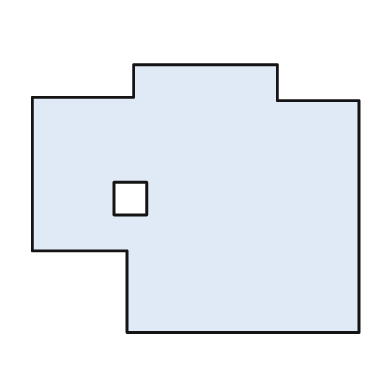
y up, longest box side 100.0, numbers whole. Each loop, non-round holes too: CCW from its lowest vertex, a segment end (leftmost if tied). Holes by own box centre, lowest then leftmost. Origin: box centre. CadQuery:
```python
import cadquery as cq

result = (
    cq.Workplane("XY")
    .moveTo(-21.0, -41.0)
    .lineTo(50.0, -41.0)
    .lineTo(50.0, 30.0)
    .lineTo(25.0, 30.0)
    .lineTo(25.0, 41.0)
    .lineTo(-19.0, 41.0)
    .lineTo(-19.0, 31.0)
    .lineTo(-50.0, 31.0)
    .lineTo(-50.0, -16.0)
    .lineTo(-21.0, -16.0)
    .close()
    .moveTo(-25.0, -5.0)
    .lineTo(-15.0, -5.0)
    .lineTo(-15.0, 5.0)
    .lineTo(-25.0, 5.0)
    .close()
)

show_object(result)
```